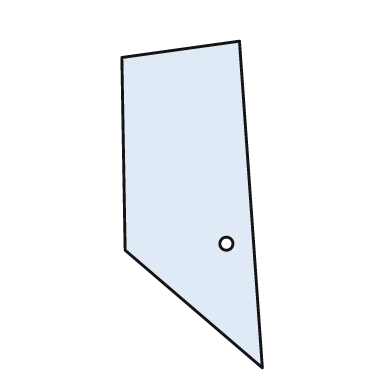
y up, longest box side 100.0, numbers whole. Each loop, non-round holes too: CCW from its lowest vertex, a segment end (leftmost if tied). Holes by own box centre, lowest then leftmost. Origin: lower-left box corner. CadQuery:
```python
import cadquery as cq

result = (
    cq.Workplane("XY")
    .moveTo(43.0, 0.0)
    .lineTo(36.0, 100.0)
    .lineTo(0.0, 95.0)
    .lineTo(1.0, 36.0)
    .close()
    .moveTo(32.0, 38.0)
    .circle(2.0)
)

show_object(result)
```